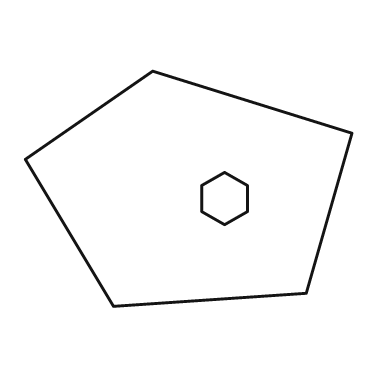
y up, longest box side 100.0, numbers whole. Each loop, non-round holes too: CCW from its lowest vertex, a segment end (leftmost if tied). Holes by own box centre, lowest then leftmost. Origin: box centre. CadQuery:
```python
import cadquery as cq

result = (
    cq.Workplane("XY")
    .moveTo(-23.0, -36.0)
    .lineTo(36.0, -32.0)
    .lineTo(50.0, 17.0)
    .lineTo(-11.0, 36.0)
    .lineTo(-50.0, 9.0)
    .close()
    .moveTo(11.0, -11.0)
    .lineTo(18.0, -7.0)
    .lineTo(18.0, 1.0)
    .lineTo(11.0, 5.0)
    .lineTo(4.0, 1.0)
    .lineTo(4.0, -7.0)
    .close()
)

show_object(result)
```